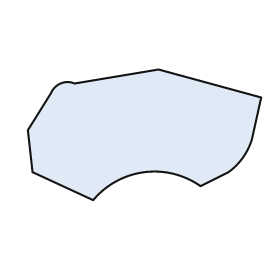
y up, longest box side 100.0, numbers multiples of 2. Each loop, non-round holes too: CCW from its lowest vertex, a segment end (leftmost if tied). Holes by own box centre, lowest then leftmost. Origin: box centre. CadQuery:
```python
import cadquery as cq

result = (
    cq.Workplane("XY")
    .moveTo(-22.0, -28.0)
    .threePointArc((0.0, -16.0), (24.0, -22.0))
    .lineTo(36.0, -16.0)
    .threePointArc((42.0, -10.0), (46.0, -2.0))
    .lineTo(50.0, 16.0)
    .lineTo(6.0, 28.0)
    .lineTo(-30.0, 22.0)
    .threePointArc((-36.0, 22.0), (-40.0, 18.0))
    .lineTo(-50.0, 2.0)
    .lineTo(-48.0, -16.0)
    .close()
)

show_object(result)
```